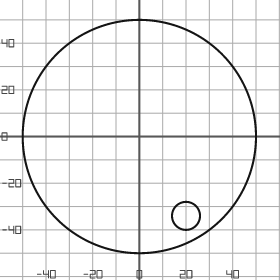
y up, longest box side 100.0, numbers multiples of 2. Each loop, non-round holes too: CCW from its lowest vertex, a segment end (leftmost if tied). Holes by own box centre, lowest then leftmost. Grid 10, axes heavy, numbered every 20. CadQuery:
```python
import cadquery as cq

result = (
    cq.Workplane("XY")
    .moveTo(0.0, 0.0)
    .circle(50.0)
    .moveTo(20.0, -34.0)
    .circle(6.0)
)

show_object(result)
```